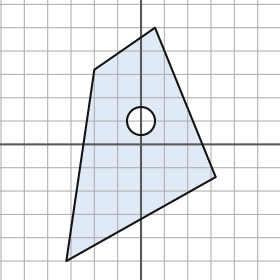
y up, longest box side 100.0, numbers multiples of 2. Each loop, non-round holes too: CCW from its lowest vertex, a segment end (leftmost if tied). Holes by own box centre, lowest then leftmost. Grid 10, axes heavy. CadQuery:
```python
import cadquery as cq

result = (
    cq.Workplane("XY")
    .moveTo(-32.0, -50.0)
    .lineTo(32.0, -14.0)
    .lineTo(6.0, 50.0)
    .lineTo(-20.0, 32.0)
    .close()
    .moveTo(0.0, 10.0)
    .circle(6.0)
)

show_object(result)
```